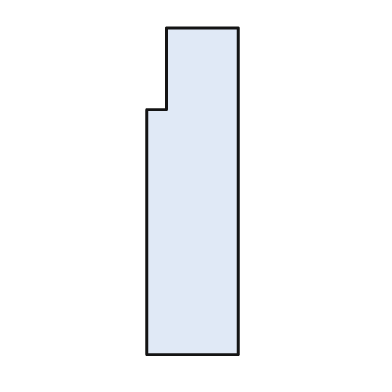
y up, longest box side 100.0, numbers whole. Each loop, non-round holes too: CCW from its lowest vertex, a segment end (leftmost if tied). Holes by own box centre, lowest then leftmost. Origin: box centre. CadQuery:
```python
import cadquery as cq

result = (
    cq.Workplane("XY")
    .moveTo(-14.0, -50.0)
    .lineTo(14.0, -50.0)
    .lineTo(14.0, 50.0)
    .lineTo(-8.0, 50.0)
    .lineTo(-8.0, 25.0)
    .lineTo(-14.0, 25.0)
    .close()
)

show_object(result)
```